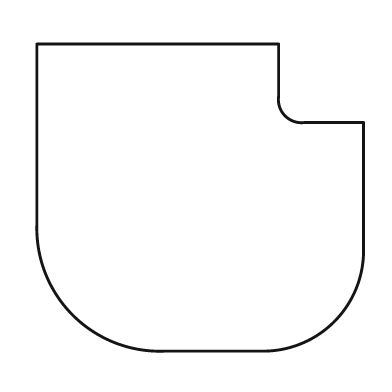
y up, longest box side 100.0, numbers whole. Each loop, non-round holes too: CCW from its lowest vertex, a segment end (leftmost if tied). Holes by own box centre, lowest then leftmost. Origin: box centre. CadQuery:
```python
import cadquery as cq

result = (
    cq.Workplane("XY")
    .moveTo(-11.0, -47.0)
    .lineTo(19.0, -47.0)
    .threePointArc((41.0, -38.0), (50.0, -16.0))
    .lineTo(50.0, 23.0)
    .lineTo(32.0, 23.0)
    .threePointArc((26.0, 25.0), (24.0, 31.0))
    .lineTo(24.0, 47.0)
    .lineTo(-50.0, 47.0)
    .lineTo(-50.0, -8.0)
    .threePointArc((-39.0, -36.0), (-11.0, -47.0))
    .close()
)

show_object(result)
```